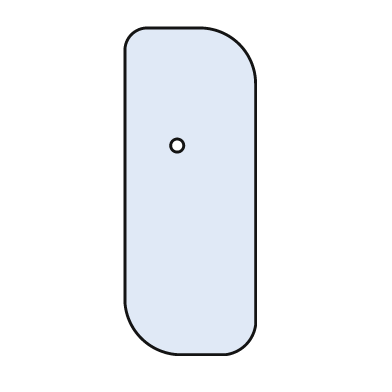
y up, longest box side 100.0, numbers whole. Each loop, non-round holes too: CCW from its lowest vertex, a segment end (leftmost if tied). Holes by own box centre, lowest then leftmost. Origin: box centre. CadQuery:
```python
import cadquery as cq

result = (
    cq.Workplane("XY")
    .moveTo(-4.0, -50.0)
    .lineTo(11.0, -50.0)
    .threePointArc((17.0, -47.0), (20.0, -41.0))
    .lineTo(20.0, 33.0)
    .threePointArc((15.0, 45.0), (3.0, 50.0))
    .lineTo(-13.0, 50.0)
    .threePointArc((-18.0, 48.0), (-20.0, 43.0))
    .lineTo(-20.0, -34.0)
    .threePointArc((-15.0, -45.0), (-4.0, -50.0))
    .close()
    .moveTo(-4.0, 14.0)
    .circle(2.0)
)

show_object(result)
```